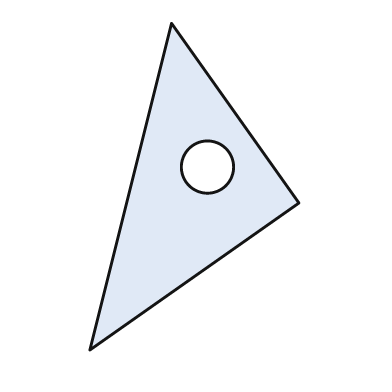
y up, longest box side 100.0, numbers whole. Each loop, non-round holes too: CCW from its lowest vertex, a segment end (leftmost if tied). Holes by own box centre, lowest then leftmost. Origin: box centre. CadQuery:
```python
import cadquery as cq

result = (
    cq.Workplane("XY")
    .moveTo(-32.0, -50.0)
    .lineTo(32.0, -5.0)
    .lineTo(-7.0, 50.0)
    .close()
    .moveTo(4.0, 6.0)
    .circle(8.0)
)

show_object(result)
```